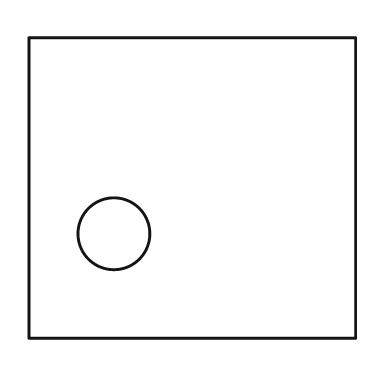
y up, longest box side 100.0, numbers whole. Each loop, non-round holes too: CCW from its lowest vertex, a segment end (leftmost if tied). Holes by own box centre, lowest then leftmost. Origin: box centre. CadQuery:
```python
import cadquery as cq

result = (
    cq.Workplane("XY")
    .moveTo(-50.0, -46.0)
    .lineTo(50.0, -46.0)
    .lineTo(50.0, 46.0)
    .lineTo(-50.0, 46.0)
    .close()
    .moveTo(-24.0, -14.0)
    .circle(11.0)
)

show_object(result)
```